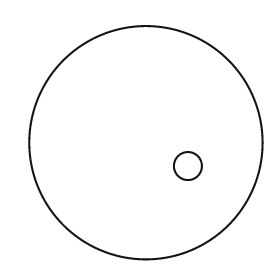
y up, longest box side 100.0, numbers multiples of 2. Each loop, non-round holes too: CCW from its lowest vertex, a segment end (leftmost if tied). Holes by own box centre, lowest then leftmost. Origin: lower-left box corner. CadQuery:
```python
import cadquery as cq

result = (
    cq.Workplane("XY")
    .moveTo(50.0, 50.0)
    .circle(50.0)
    .moveTo(68.0, 40.0)
    .circle(6.0)
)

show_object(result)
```